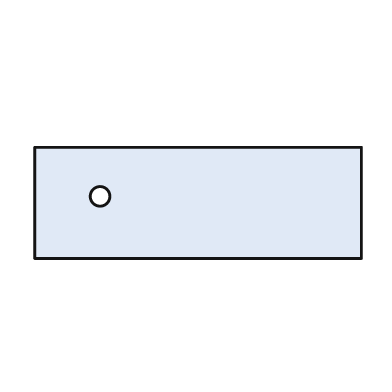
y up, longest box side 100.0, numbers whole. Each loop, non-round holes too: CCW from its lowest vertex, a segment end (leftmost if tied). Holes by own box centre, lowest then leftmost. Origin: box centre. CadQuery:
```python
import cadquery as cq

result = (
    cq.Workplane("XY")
    .moveTo(-50.0, -17.0)
    .lineTo(50.0, -17.0)
    .lineTo(50.0, 17.0)
    .lineTo(-50.0, 17.0)
    .close()
    .moveTo(-30.0, 2.0)
    .circle(3.0)
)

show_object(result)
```